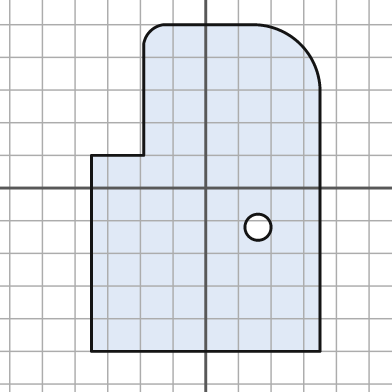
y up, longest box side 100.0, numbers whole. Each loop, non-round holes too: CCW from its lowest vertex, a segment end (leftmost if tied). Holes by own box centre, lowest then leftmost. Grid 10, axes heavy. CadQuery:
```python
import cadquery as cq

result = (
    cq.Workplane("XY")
    .moveTo(-35.0, -50.0)
    .lineTo(35.0, -50.0)
    .lineTo(35.0, 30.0)
    .threePointArc((29.0, 44.0), (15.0, 50.0))
    .lineTo(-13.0, 50.0)
    .threePointArc((-17.0, 48.0), (-19.0, 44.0))
    .lineTo(-19.0, 10.0)
    .lineTo(-35.0, 10.0)
    .close()
    .moveTo(16.0, -12.0)
    .circle(4.0)
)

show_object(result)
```